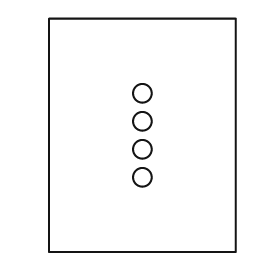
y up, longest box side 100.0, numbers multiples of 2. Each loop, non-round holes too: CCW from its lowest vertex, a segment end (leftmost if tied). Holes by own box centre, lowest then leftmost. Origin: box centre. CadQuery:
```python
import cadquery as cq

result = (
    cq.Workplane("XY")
    .moveTo(-40.0, -50.0)
    .lineTo(40.0, -50.0)
    .lineTo(40.0, 50.0)
    .lineTo(-40.0, 50.0)
    .close()
    .moveTo(0.0, -18.0)
    .circle(4.0)
    .moveTo(0.0, -6.0)
    .circle(4.0)
    .moveTo(0.0, 6.0)
    .circle(4.0)
    .moveTo(0.0, 18.0)
    .circle(4.0)
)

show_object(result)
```